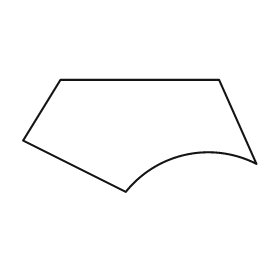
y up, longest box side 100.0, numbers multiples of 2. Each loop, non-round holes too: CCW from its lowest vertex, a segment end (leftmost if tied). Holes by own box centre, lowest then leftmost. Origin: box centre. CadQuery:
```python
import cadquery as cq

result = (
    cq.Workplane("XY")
    .moveTo(-6.0, -24.0)
    .threePointArc((20.0, -8.0), (50.0, -12.0))
    .lineTo(34.0, 24.0)
    .lineTo(-34.0, 24.0)
    .lineTo(-50.0, -2.0)
    .close()
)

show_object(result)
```